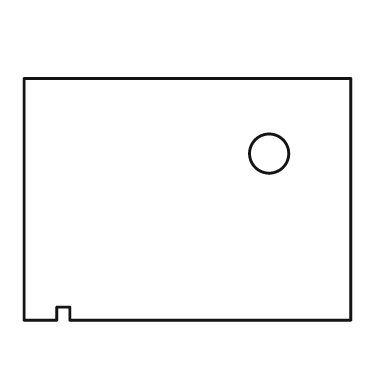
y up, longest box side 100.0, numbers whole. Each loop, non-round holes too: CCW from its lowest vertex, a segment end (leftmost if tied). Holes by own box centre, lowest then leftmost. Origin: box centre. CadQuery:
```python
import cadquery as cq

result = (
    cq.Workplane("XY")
    .moveTo(-50.0, -37.0)
    .lineTo(-40.0, -37.0)
    .lineTo(-40.0, -33.0)
    .lineTo(-36.0, -33.0)
    .lineTo(-36.0, -37.0)
    .lineTo(50.0, -37.0)
    .lineTo(50.0, 37.0)
    .lineTo(-50.0, 37.0)
    .close()
    .moveTo(25.0, 14.0)
    .circle(6.0)
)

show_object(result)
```